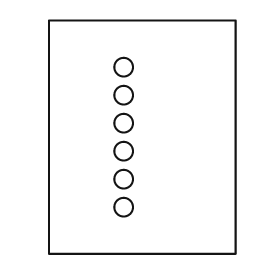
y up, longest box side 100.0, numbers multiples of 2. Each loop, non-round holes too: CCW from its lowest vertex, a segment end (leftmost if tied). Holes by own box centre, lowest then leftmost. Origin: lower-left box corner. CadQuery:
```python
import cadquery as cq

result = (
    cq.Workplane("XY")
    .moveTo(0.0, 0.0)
    .lineTo(80.0, 0.0)
    .lineTo(80.0, 100.0)
    .lineTo(0.0, 100.0)
    .close()
    .moveTo(32.0, 20.0)
    .circle(4.0)
    .moveTo(32.0, 32.0)
    .circle(4.0)
    .moveTo(32.0, 44.0)
    .circle(4.0)
    .moveTo(32.0, 56.0)
    .circle(4.0)
    .moveTo(32.0, 68.0)
    .circle(4.0)
    .moveTo(32.0, 80.0)
    .circle(4.0)
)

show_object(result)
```